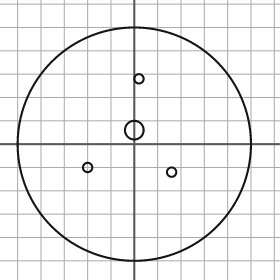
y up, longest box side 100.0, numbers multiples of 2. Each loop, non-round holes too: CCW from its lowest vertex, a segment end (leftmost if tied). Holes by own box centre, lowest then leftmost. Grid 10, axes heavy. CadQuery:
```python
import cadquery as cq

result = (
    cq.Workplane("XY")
    .moveTo(0.0, 0.0)
    .circle(50.0)
    .moveTo(16.0, -12.0)
    .circle(2.0)
    .moveTo(-20.0, -10.0)
    .circle(2.0)
    .moveTo(0.0, 6.0)
    .circle(4.0)
    .moveTo(2.0, 28.0)
    .circle(2.0)
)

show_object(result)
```